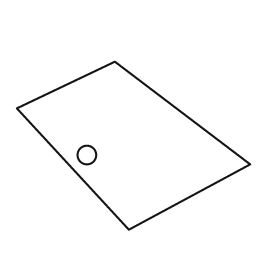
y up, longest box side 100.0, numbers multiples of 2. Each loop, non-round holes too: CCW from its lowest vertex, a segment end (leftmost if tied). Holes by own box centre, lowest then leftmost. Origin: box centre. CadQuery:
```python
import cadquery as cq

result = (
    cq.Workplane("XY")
    .moveTo(-2.0, -36.0)
    .lineTo(50.0, -8.0)
    .lineTo(-8.0, 36.0)
    .lineTo(-50.0, 16.0)
    .close()
    .moveTo(-20.0, -4.0)
    .circle(4.0)
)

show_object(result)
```